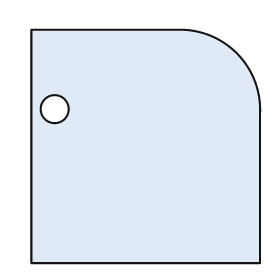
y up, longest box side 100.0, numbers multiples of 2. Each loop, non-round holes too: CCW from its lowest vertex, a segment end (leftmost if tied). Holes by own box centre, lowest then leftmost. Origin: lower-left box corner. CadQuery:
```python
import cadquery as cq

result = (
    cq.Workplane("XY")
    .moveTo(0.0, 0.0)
    .lineTo(98.0, 0.0)
    .lineTo(98.0, 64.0)
    .threePointArc((88.0, 90.0), (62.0, 100.0))
    .lineTo(0.0, 100.0)
    .close()
    .moveTo(10.0, 66.0)
    .circle(6.0)
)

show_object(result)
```